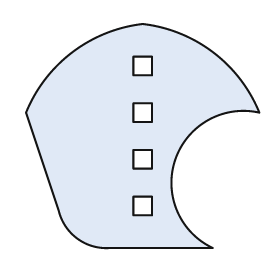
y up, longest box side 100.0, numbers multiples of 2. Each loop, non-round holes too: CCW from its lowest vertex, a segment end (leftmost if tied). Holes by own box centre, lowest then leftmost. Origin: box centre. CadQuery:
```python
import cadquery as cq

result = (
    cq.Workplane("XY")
    .moveTo(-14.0, -48.0)
    .lineTo(30.0, -48.0)
    .threePointArc((14.0, -10.0), (50.0, 10.0))
    .threePointArc((30.0, 36.0), (0.0, 48.0))
    .threePointArc((-30.0, 36.0), (-50.0, 10.0))
    .lineTo(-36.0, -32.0)
    .threePointArc((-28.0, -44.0), (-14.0, -48.0))
    .close()
    .moveTo(-4.0, -34.0)
    .lineTo(4.0, -34.0)
    .lineTo(4.0, -26.0)
    .lineTo(-4.0, -26.0)
    .close()
    .moveTo(-4.0, -14.0)
    .lineTo(4.0, -14.0)
    .lineTo(4.0, -6.0)
    .lineTo(-4.0, -6.0)
    .close()
    .moveTo(-4.0, 6.0)
    .lineTo(4.0, 6.0)
    .lineTo(4.0, 14.0)
    .lineTo(-4.0, 14.0)
    .close()
    .moveTo(-4.0, 26.0)
    .lineTo(4.0, 26.0)
    .lineTo(4.0, 34.0)
    .lineTo(-4.0, 34.0)
    .close()
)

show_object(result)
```